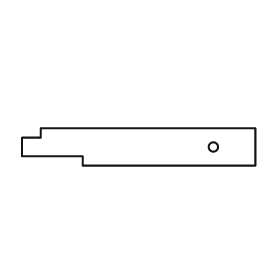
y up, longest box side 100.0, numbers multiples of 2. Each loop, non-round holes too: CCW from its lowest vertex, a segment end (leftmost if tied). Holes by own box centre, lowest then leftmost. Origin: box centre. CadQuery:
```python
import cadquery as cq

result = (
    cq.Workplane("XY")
    .moveTo(-24.0, -8.0)
    .lineTo(50.0, -8.0)
    .lineTo(50.0, 8.0)
    .lineTo(-42.0, 8.0)
    .lineTo(-42.0, 4.0)
    .lineTo(-50.0, 4.0)
    .lineTo(-50.0, -4.0)
    .lineTo(-24.0, -4.0)
    .close()
    .moveTo(32.0, 0.0)
    .circle(2.0)
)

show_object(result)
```